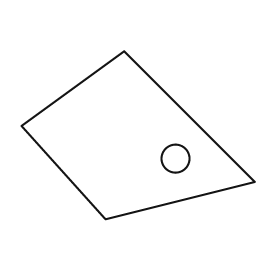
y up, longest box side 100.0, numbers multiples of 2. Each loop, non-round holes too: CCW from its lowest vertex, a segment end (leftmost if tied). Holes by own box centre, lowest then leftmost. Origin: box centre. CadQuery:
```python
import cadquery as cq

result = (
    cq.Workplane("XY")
    .moveTo(-14.0, -36.0)
    .lineTo(50.0, -20.0)
    .lineTo(-6.0, 36.0)
    .lineTo(-50.0, 4.0)
    .close()
    .moveTo(16.0, -10.0)
    .circle(6.0)
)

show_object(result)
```